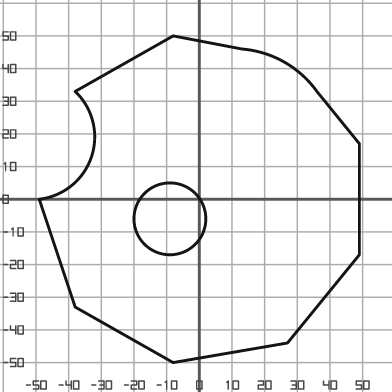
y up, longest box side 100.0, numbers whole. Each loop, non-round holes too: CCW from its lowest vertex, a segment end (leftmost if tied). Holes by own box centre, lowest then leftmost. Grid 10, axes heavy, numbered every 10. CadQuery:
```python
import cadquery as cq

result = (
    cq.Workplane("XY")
    .moveTo(-8.0, -50.0)
    .lineTo(27.0, -44.0)
    .lineTo(49.0, -17.0)
    .lineTo(49.0, 17.0)
    .lineTo(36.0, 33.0)
    .threePointArc((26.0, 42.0), (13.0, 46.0))
    .lineTo(-8.0, 50.0)
    .lineTo(-38.0, 33.0)
    .threePointArc((-33.0, 13.0), (-49.0, 0.0))
    .lineTo(-38.0, -33.0)
    .close()
    .moveTo(-9.0, -6.0)
    .circle(11.0)
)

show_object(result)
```